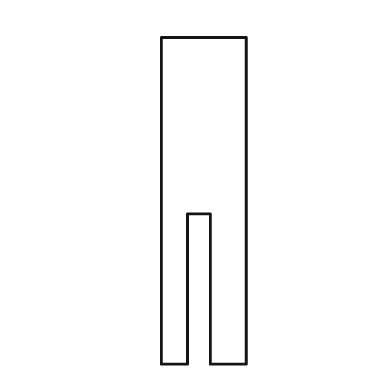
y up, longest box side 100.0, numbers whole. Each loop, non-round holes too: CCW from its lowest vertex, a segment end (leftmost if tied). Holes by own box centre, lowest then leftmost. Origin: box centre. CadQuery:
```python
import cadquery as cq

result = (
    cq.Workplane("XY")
    .moveTo(-13.0, -50.0)
    .lineTo(-5.0, -50.0)
    .lineTo(-5.0, -4.0)
    .lineTo(2.0, -4.0)
    .lineTo(2.0, -50.0)
    .lineTo(13.0, -50.0)
    .lineTo(13.0, 50.0)
    .lineTo(-13.0, 50.0)
    .close()
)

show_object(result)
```